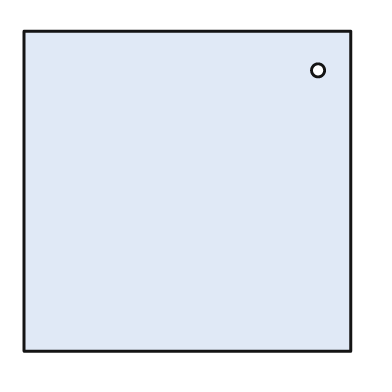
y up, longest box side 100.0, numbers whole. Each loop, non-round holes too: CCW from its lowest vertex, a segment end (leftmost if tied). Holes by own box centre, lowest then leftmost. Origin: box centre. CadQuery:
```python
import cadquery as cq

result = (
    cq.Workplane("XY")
    .moveTo(-50.0, -49.0)
    .lineTo(50.0, -49.0)
    .lineTo(50.0, 49.0)
    .lineTo(-50.0, 49.0)
    .close()
    .moveTo(40.0, 37.0)
    .circle(2.0)
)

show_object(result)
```